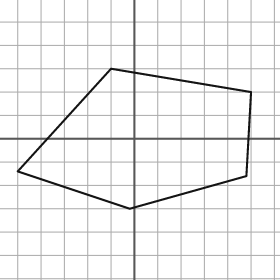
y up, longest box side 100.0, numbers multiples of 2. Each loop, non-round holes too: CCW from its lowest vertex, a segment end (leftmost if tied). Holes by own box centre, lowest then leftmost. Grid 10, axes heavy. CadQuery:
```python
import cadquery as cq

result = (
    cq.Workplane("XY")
    .moveTo(-2.0, -30.0)
    .lineTo(48.0, -16.0)
    .lineTo(50.0, 20.0)
    .lineTo(-10.0, 30.0)
    .lineTo(-50.0, -14.0)
    .close()
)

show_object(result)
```